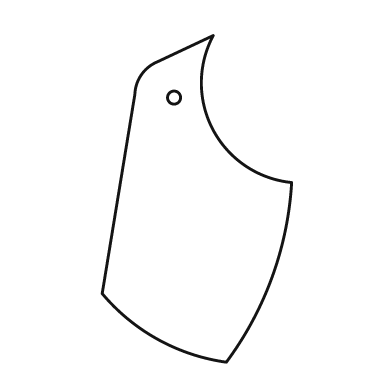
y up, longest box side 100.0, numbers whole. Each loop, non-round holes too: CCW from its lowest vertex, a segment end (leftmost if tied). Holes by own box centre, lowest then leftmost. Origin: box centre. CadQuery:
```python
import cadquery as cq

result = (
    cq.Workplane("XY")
    .moveTo(9.0, -50.0)
    .threePointArc((23.0, -24.0), (29.0, 5.0))
    .threePointArc((5.0, 21.0), (5.0, 50.0))
    .lineTo(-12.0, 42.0)
    .threePointArc((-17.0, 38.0), (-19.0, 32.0))
    .lineTo(-29.0, -29.0)
    .threePointArc((-12.0, -43.0), (9.0, -50.0))
    .close()
    .moveTo(-7.0, 31.0)
    .circle(2.0)
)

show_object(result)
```